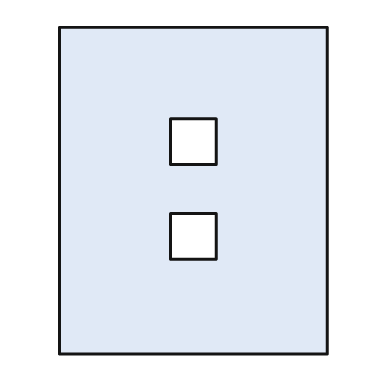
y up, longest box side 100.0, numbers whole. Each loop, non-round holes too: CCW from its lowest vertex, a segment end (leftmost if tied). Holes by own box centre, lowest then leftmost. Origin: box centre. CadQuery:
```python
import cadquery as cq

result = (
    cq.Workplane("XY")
    .moveTo(-41.0, -50.0)
    .lineTo(41.0, -50.0)
    .lineTo(41.0, 50.0)
    .lineTo(-41.0, 50.0)
    .close()
    .moveTo(-7.0, -21.0)
    .lineTo(7.0, -21.0)
    .lineTo(7.0, -7.0)
    .lineTo(-7.0, -7.0)
    .close()
    .moveTo(-7.0, 8.0)
    .lineTo(7.0, 8.0)
    .lineTo(7.0, 22.0)
    .lineTo(-7.0, 22.0)
    .close()
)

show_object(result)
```